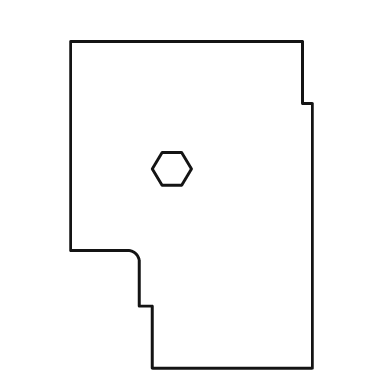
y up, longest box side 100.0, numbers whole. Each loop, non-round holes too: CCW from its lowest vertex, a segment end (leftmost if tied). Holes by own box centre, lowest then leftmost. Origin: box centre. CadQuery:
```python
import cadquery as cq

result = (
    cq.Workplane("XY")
    .moveTo(-12.0, -50.0)
    .lineTo(37.0, -50.0)
    .lineTo(37.0, 31.0)
    .lineTo(34.0, 31.0)
    .lineTo(34.0, 50.0)
    .lineTo(-37.0, 50.0)
    .lineTo(-37.0, -14.0)
    .lineTo(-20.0, -14.0)
    .threePointArc((-17.0, -15.0), (-16.0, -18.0))
    .lineTo(-16.0, -31.0)
    .lineTo(-12.0, -31.0)
    .close()
    .moveTo(-9.0, 6.0)
    .lineTo(-3.0, 6.0)
    .lineTo(0.0, 11.0)
    .lineTo(-3.0, 16.0)
    .lineTo(-9.0, 16.0)
    .lineTo(-12.0, 11.0)
    .close()
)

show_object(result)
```